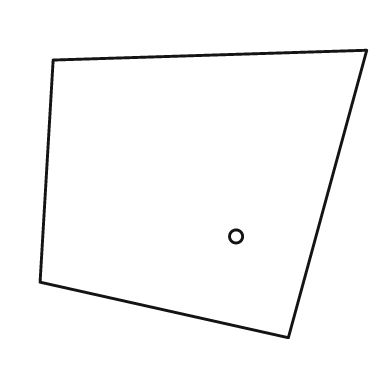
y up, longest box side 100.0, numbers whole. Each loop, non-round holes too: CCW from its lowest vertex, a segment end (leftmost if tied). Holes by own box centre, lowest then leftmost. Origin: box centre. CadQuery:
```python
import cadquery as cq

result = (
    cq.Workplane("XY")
    .moveTo(26.0, -44.0)
    .lineTo(50.0, 44.0)
    .lineTo(-46.0, 41.0)
    .lineTo(-50.0, -27.0)
    .close()
    .moveTo(10.0, -13.0)
    .circle(2.0)
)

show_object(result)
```